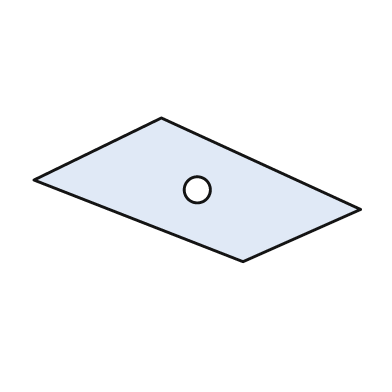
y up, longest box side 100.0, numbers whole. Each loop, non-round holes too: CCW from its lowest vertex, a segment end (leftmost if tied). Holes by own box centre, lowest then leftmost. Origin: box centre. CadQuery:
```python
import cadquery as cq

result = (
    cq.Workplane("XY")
    .moveTo(14.0, -22.0)
    .lineTo(50.0, -6.0)
    .lineTo(-11.0, 22.0)
    .lineTo(-50.0, 3.0)
    .close()
    .moveTo(0.0, 0.0)
    .circle(4.0)
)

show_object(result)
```